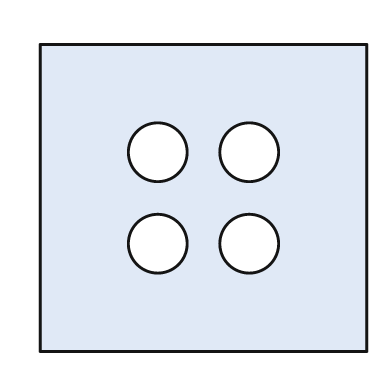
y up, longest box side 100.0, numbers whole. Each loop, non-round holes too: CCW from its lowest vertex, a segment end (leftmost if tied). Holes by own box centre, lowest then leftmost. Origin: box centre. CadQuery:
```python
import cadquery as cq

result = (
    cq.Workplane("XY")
    .moveTo(-50.0, -47.0)
    .lineTo(50.0, -47.0)
    .lineTo(50.0, 47.0)
    .lineTo(-50.0, 47.0)
    .close()
    .moveTo(-14.0, -14.0)
    .circle(9.0)
    .moveTo(14.0, -14.0)
    .circle(9.0)
    .moveTo(-14.0, 14.0)
    .circle(9.0)
    .moveTo(14.0, 14.0)
    .circle(9.0)
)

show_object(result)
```